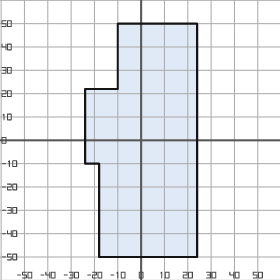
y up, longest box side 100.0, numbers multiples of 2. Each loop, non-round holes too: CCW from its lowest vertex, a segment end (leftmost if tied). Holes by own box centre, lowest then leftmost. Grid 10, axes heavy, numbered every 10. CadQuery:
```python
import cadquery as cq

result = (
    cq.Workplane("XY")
    .moveTo(-18.0, -50.0)
    .lineTo(24.0, -50.0)
    .lineTo(24.0, 50.0)
    .lineTo(-10.0, 50.0)
    .lineTo(-10.0, 22.0)
    .lineTo(-24.0, 22.0)
    .lineTo(-24.0, -10.0)
    .lineTo(-18.0, -10.0)
    .close()
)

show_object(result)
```